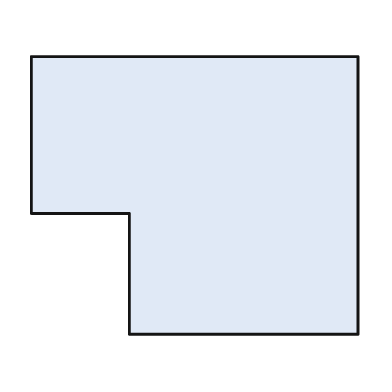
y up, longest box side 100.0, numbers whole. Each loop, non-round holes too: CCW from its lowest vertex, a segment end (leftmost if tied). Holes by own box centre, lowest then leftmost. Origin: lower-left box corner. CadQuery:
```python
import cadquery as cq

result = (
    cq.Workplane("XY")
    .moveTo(30.0, 0.0)
    .lineTo(100.0, 0.0)
    .lineTo(100.0, 85.0)
    .lineTo(0.0, 85.0)
    .lineTo(0.0, 37.0)
    .lineTo(30.0, 37.0)
    .close()
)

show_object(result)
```